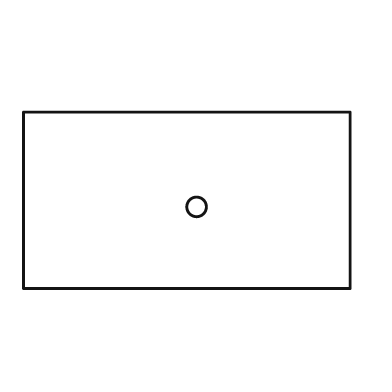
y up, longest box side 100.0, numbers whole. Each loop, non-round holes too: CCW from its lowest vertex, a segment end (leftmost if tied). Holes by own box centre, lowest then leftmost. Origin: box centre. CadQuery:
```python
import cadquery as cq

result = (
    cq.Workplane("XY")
    .moveTo(-50.0, -27.0)
    .lineTo(50.0, -27.0)
    .lineTo(50.0, 27.0)
    .lineTo(-50.0, 27.0)
    .close()
    .moveTo(3.0, -2.0)
    .circle(3.0)
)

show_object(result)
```